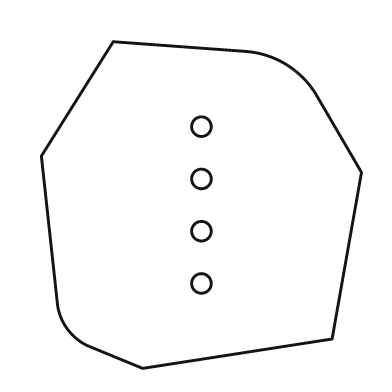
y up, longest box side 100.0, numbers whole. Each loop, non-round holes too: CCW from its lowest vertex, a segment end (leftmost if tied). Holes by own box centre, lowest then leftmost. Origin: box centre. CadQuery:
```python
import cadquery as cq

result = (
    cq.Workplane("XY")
    .moveTo(-18.0, -50.0)
    .lineTo(40.0, -41.0)
    .lineTo(49.0, 10.0)
    .lineTo(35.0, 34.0)
    .threePointArc((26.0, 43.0), (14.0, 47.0))
    .lineTo(-27.0, 50.0)
    .lineTo(-49.0, 15.0)
    .lineTo(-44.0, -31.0)
    .threePointArc((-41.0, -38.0), (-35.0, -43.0))
    .close()
    .moveTo(0.0, -24.0)
    .circle(3.0)
    .moveTo(0.0, -8.0)
    .circle(3.0)
    .moveTo(0.0, 8.0)
    .circle(3.0)
    .moveTo(0.0, 24.0)
    .circle(3.0)
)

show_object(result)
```